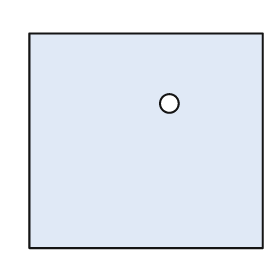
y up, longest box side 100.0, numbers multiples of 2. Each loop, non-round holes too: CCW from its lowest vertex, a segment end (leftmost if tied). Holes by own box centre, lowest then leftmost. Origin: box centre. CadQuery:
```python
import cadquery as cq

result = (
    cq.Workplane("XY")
    .moveTo(-50.0, -46.0)
    .lineTo(50.0, -46.0)
    .lineTo(50.0, 46.0)
    .lineTo(-50.0, 46.0)
    .close()
    .moveTo(10.0, 16.0)
    .circle(4.0)
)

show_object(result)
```